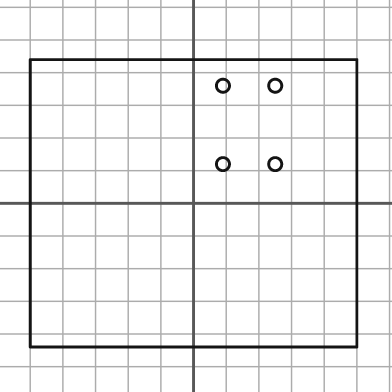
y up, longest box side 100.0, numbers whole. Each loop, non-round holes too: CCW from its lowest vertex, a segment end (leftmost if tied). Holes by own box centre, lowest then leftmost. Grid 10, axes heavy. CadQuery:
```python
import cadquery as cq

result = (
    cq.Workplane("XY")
    .moveTo(-50.0, -44.0)
    .lineTo(50.0, -44.0)
    .lineTo(50.0, 44.0)
    .lineTo(-50.0, 44.0)
    .close()
    .moveTo(9.0, 12.0)
    .circle(2.0)
    .moveTo(25.0, 12.0)
    .circle(2.0)
    .moveTo(9.0, 36.0)
    .circle(2.0)
    .moveTo(25.0, 36.0)
    .circle(2.0)
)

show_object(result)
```